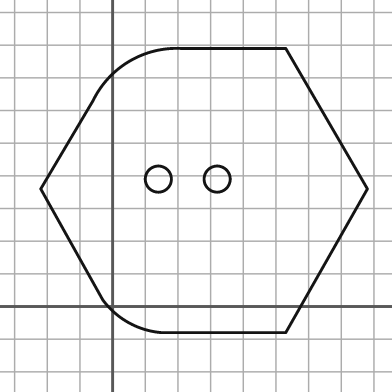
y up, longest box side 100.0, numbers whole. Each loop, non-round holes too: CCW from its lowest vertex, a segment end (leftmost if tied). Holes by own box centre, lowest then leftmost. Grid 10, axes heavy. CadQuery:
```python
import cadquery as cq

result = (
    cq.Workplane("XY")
    .moveTo(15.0, -8.0)
    .lineTo(53.0, -8.0)
    .lineTo(78.0, 36.0)
    .lineTo(53.0, 79.0)
    .lineTo(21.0, 79.0)
    .threePointArc((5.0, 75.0), (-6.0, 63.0))
    .lineTo(-22.0, 36.0)
    .lineTo(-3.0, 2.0)
    .threePointArc((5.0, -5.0), (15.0, -8.0))
    .close()
    .moveTo(14.0, 39.0)
    .circle(4.0)
    .moveTo(32.0, 39.0)
    .circle(4.0)
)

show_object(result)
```